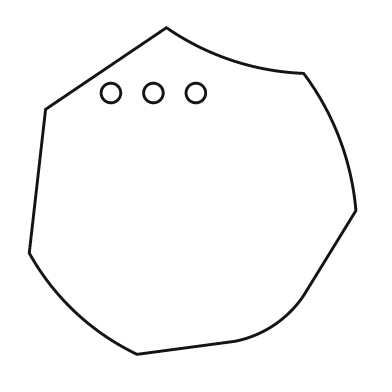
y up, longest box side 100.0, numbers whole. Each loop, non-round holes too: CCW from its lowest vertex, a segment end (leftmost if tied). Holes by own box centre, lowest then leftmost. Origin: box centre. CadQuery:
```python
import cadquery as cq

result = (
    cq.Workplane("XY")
    .moveTo(-17.0, -50.0)
    .lineTo(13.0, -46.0)
    .threePointArc((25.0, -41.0), (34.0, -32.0))
    .lineTo(50.0, -6.0)
    .threePointArc((45.0, 16.0), (34.0, 36.0))
    .threePointArc((12.0, 40.0), (-8.0, 50.0))
    .lineTo(-45.0, 25.0)
    .lineTo(-50.0, -19.0)
    .threePointArc((-36.0, -37.0), (-17.0, -50.0))
    .close()
    .moveTo(-25.0, 30.0)
    .circle(3.0)
    .moveTo(-12.0, 30.0)
    .circle(3.0)
    .moveTo(1.0, 30.0)
    .circle(3.0)
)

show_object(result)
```